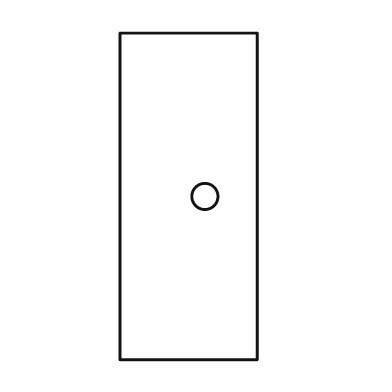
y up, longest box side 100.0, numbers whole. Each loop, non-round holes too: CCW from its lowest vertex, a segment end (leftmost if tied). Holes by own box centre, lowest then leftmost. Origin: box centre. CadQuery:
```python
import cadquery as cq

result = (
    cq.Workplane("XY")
    .moveTo(-21.0, -50.0)
    .lineTo(21.0, -50.0)
    .lineTo(21.0, 50.0)
    .lineTo(-21.0, 50.0)
    .close()
    .moveTo(5.0, 0.0)
    .circle(4.0)
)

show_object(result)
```